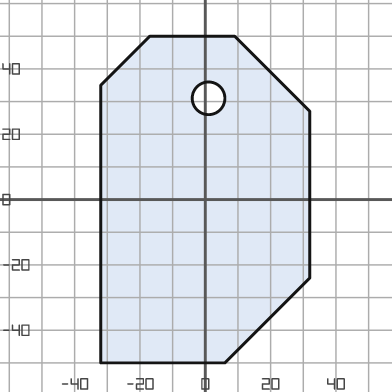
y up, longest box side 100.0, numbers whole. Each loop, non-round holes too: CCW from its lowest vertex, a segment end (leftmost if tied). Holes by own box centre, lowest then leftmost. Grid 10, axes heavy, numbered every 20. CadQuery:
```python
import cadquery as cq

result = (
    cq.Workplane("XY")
    .moveTo(-32.0, -50.0)
    .lineTo(6.0, -50.0)
    .lineTo(32.0, -24.0)
    .lineTo(32.0, 27.0)
    .lineTo(9.0, 50.0)
    .lineTo(-17.0, 50.0)
    .lineTo(-32.0, 35.0)
    .close()
    .moveTo(1.0, 31.0)
    .circle(5.0)
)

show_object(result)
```